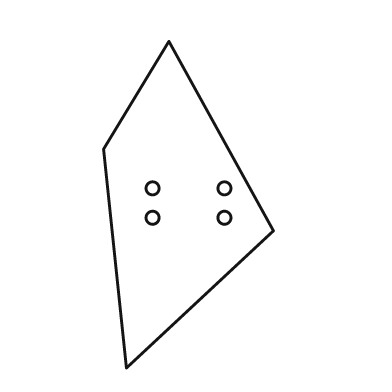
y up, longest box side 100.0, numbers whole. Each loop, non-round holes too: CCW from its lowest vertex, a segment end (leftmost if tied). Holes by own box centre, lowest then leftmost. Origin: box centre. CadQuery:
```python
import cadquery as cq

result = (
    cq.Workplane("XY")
    .moveTo(-19.0, -50.0)
    .lineTo(26.0, -8.0)
    .lineTo(-6.0, 50.0)
    .lineTo(-26.0, 17.0)
    .close()
    .moveTo(-11.0, -4.0)
    .circle(2.0)
    .moveTo(11.0, -4.0)
    .circle(2.0)
    .moveTo(-11.0, 5.0)
    .circle(2.0)
    .moveTo(11.0, 5.0)
    .circle(2.0)
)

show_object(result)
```